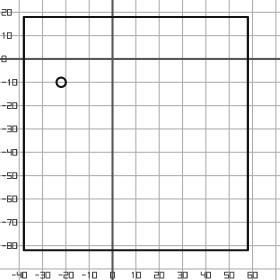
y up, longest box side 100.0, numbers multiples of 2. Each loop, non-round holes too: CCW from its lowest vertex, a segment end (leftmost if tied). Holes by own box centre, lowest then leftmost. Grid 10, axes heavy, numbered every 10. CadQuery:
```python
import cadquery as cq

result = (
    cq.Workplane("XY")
    .moveTo(-38.0, -82.0)
    .lineTo(58.0, -82.0)
    .lineTo(58.0, 18.0)
    .lineTo(-38.0, 18.0)
    .close()
    .moveTo(-22.0, -10.0)
    .circle(2.0)
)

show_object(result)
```